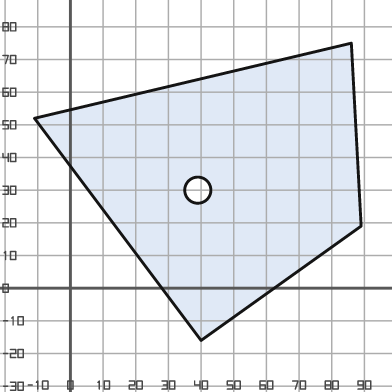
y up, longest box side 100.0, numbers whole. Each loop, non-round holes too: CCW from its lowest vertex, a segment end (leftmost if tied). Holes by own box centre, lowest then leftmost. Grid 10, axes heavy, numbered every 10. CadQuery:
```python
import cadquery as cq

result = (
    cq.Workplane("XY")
    .moveTo(40.0, -16.0)
    .lineTo(89.0, 19.0)
    .lineTo(86.0, 75.0)
    .lineTo(-11.0, 52.0)
    .close()
    .moveTo(39.0, 30.0)
    .circle(4.0)
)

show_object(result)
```